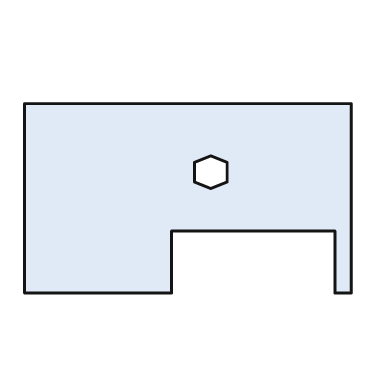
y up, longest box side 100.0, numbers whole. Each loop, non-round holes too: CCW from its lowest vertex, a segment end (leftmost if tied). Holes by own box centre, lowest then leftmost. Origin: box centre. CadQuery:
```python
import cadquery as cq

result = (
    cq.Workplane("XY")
    .moveTo(-50.0, -29.0)
    .lineTo(-5.0, -29.0)
    .lineTo(-5.0, -10.0)
    .lineTo(45.0, -10.0)
    .lineTo(45.0, -29.0)
    .lineTo(50.0, -29.0)
    .lineTo(50.0, 29.0)
    .lineTo(-50.0, 29.0)
    .close()
    .moveTo(7.0, 3.0)
    .lineTo(12.0, 5.0)
    .lineTo(12.0, 11.0)
    .lineTo(7.0, 13.0)
    .lineTo(2.0, 11.0)
    .lineTo(2.0, 5.0)
    .close()
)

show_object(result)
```